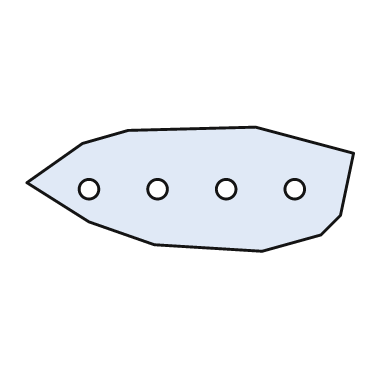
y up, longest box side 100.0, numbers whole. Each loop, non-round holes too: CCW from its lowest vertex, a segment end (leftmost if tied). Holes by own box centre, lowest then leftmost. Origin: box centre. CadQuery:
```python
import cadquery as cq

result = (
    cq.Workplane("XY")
    .moveTo(22.0, -19.0)
    .lineTo(40.0, -14.0)
    .lineTo(46.0, -8.0)
    .lineTo(50.0, 11.0)
    .lineTo(20.0, 19.0)
    .lineTo(-19.0, 18.0)
    .lineTo(-33.0, 14.0)
    .lineTo(-50.0, 2.0)
    .lineTo(-31.0, -10.0)
    .lineTo(-11.0, -17.0)
    .close()
    .moveTo(-31.0, 0.0)
    .circle(3.0)
    .moveTo(-10.0, 0.0)
    .circle(3.0)
    .moveTo(11.0, 0.0)
    .circle(3.0)
    .moveTo(32.0, 0.0)
    .circle(3.0)
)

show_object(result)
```